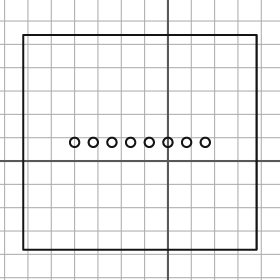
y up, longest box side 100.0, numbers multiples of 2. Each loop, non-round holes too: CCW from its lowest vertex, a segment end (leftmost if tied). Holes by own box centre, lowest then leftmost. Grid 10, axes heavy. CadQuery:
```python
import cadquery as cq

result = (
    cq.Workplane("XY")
    .moveTo(-62.0, -38.0)
    .lineTo(38.0, -38.0)
    .lineTo(38.0, 54.0)
    .lineTo(-62.0, 54.0)
    .close()
    .moveTo(-40.0, 8.0)
    .circle(2.0)
    .moveTo(-32.0, 8.0)
    .circle(2.0)
    .moveTo(-24.0, 8.0)
    .circle(2.0)
    .moveTo(-16.0, 8.0)
    .circle(2.0)
    .moveTo(-8.0, 8.0)
    .circle(2.0)
    .moveTo(0.0, 8.0)
    .circle(2.0)
    .moveTo(8.0, 8.0)
    .circle(2.0)
    .moveTo(16.0, 8.0)
    .circle(2.0)
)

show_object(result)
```